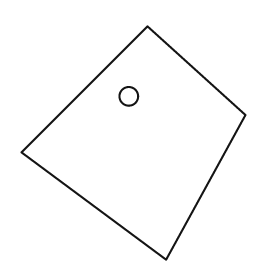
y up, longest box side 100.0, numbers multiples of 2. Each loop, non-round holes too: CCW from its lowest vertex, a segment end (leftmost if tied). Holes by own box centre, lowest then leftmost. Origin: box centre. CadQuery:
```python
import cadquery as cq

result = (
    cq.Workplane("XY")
    .moveTo(14.0, -50.0)
    .lineTo(48.0, 12.0)
    .lineTo(6.0, 50.0)
    .lineTo(-48.0, -4.0)
    .close()
    .moveTo(-2.0, 20.0)
    .circle(4.0)
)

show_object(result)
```